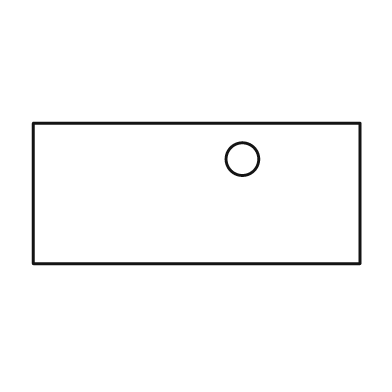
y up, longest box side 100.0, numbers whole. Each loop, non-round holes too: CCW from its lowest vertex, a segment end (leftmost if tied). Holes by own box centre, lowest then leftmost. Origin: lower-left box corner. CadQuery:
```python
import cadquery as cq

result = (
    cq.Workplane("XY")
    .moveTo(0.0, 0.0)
    .lineTo(100.0, 0.0)
    .lineTo(100.0, 43.0)
    .lineTo(0.0, 43.0)
    .close()
    .moveTo(64.0, 32.0)
    .circle(5.0)
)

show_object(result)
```